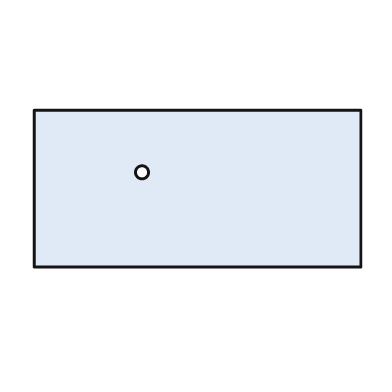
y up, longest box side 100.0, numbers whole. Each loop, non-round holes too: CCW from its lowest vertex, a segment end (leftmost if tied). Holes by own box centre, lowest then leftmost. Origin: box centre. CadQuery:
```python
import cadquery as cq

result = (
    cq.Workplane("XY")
    .moveTo(-50.0, -24.0)
    .lineTo(50.0, -24.0)
    .lineTo(50.0, 24.0)
    .lineTo(-50.0, 24.0)
    .close()
    .moveTo(-17.0, 5.0)
    .circle(2.0)
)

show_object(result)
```